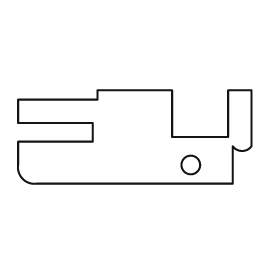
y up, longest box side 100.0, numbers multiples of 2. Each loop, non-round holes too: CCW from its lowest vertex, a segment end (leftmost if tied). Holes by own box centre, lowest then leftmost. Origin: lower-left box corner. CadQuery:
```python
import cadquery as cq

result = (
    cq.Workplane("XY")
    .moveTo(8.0, 0.0)
    .lineTo(92.0, 0.0)
    .lineTo(92.0, 16.0)
    .threePointArc((96.0, 14.0), (100.0, 16.0))
    .lineTo(100.0, 40.0)
    .lineTo(90.0, 40.0)
    .lineTo(90.0, 20.0)
    .lineTo(66.0, 20.0)
    .lineTo(66.0, 40.0)
    .lineTo(34.0, 40.0)
    .lineTo(34.0, 36.0)
    .lineTo(0.0, 36.0)
    .lineTo(0.0, 26.0)
    .lineTo(32.0, 26.0)
    .lineTo(32.0, 18.0)
    .lineTo(0.0, 18.0)
    .lineTo(0.0, 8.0)
    .threePointArc((2.0, 2.0), (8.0, 0.0))
    .close()
    .moveTo(74.0, 8.0)
    .circle(4.0)
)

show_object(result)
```